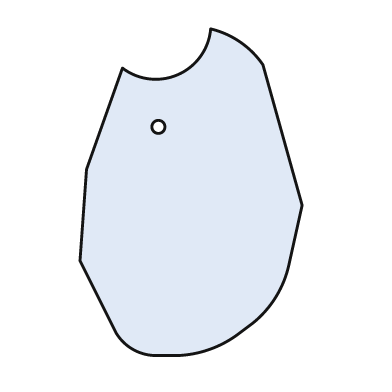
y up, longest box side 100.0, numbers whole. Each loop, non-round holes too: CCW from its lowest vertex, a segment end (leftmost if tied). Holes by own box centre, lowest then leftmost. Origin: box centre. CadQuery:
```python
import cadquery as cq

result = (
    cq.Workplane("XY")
    .moveTo(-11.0, -50.0)
    .lineTo(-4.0, -50.0)
    .threePointArc((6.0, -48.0), (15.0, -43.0))
    .lineTo(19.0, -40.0)
    .threePointArc((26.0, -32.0), (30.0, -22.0))
    .lineTo(34.0, -4.0)
    .lineTo(22.0, 39.0)
    .threePointArc((15.0, 46.0), (6.0, 50.0))
    .threePointArc((-4.0, 36.0), (-21.0, 38.0))
    .lineTo(-32.0, 7.0)
    .lineTo(-34.0, -21.0)
    .lineTo(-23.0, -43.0)
    .threePointArc((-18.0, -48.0), (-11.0, -50.0))
    .close()
    .moveTo(-10.0, 20.0)
    .circle(2.0)
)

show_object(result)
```